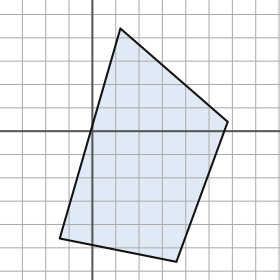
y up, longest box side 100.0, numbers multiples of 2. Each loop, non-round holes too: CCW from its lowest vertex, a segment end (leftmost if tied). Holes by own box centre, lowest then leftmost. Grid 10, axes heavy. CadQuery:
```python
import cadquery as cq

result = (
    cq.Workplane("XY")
    .moveTo(36.0, -56.0)
    .lineTo(58.0, 4.0)
    .lineTo(12.0, 44.0)
    .lineTo(-14.0, -46.0)
    .close()
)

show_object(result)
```